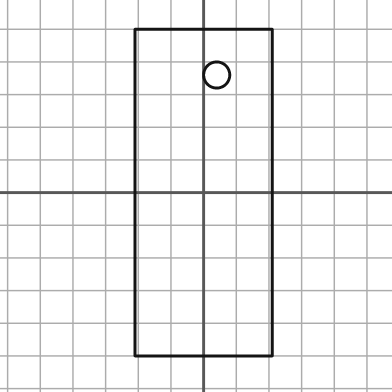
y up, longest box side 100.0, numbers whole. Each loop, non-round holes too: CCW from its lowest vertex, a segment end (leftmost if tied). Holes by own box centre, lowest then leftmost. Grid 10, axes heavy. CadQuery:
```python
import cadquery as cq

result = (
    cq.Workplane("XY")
    .moveTo(-21.0, -50.0)
    .lineTo(21.0, -50.0)
    .lineTo(21.0, 50.0)
    .lineTo(-21.0, 50.0)
    .close()
    .moveTo(4.0, 36.0)
    .circle(4.0)
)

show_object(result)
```